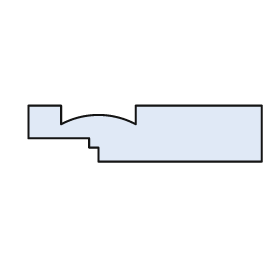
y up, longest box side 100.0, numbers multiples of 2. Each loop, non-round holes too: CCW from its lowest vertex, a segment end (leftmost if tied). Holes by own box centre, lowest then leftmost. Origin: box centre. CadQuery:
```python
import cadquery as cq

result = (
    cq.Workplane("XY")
    .moveTo(-20.0, -12.0)
    .lineTo(50.0, -12.0)
    .lineTo(50.0, 12.0)
    .lineTo(-4.0, 12.0)
    .lineTo(-4.0, 4.0)
    .threePointArc((-20.0, 8.0), (-36.0, 4.0))
    .lineTo(-36.0, 12.0)
    .lineTo(-50.0, 12.0)
    .lineTo(-50.0, -2.0)
    .lineTo(-24.0, -2.0)
    .lineTo(-24.0, -6.0)
    .lineTo(-20.0, -6.0)
    .close()
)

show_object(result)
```